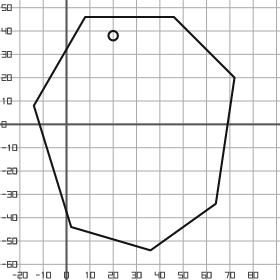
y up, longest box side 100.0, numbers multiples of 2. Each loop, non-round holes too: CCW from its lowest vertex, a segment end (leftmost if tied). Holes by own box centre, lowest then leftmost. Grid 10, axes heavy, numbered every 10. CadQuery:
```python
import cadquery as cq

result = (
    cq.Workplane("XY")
    .moveTo(36.0, -54.0)
    .lineTo(64.0, -34.0)
    .lineTo(72.0, 20.0)
    .lineTo(46.0, 46.0)
    .lineTo(8.0, 46.0)
    .lineTo(-14.0, 8.0)
    .lineTo(2.0, -44.0)
    .close()
    .moveTo(20.0, 38.0)
    .circle(2.0)
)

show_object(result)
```